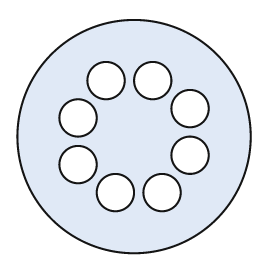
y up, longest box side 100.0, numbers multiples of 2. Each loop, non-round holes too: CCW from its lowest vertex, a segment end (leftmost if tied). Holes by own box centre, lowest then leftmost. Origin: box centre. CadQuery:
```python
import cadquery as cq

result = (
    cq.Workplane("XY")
    .moveTo(0.0, 0.0)
    .circle(50.0)
    .moveTo(-8.0, -24.0)
    .circle(8.0)
    .moveTo(12.0, -24.0)
    .circle(8.0)
    .moveTo(-24.0, -12.0)
    .circle(8.0)
    .moveTo(24.0, -8.0)
    .circle(8.0)
    .moveTo(-24.0, 8.0)
    .circle(8.0)
    .moveTo(24.0, 12.0)
    .circle(8.0)
    .moveTo(-12.0, 24.0)
    .circle(8.0)
    .moveTo(8.0, 24.0)
    .circle(8.0)
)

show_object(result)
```